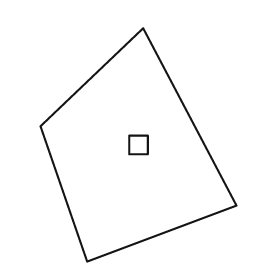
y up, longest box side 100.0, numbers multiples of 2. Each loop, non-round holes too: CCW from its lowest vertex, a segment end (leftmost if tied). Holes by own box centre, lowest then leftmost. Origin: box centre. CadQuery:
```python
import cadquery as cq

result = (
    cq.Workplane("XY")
    .moveTo(-22.0, -50.0)
    .lineTo(42.0, -26.0)
    .lineTo(2.0, 50.0)
    .lineTo(-42.0, 8.0)
    .close()
    .moveTo(-4.0, -4.0)
    .lineTo(4.0, -4.0)
    .lineTo(4.0, 4.0)
    .lineTo(-4.0, 4.0)
    .close()
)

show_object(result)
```